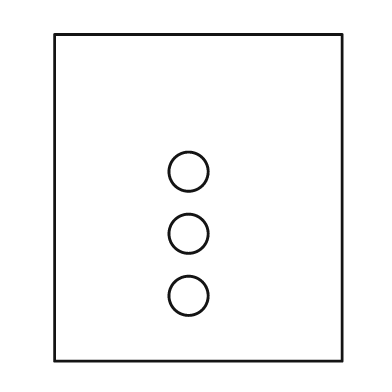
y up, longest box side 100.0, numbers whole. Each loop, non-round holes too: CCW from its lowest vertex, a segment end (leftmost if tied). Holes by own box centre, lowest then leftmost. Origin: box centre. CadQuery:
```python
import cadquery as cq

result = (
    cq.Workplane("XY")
    .moveTo(-44.0, -50.0)
    .lineTo(44.0, -50.0)
    .lineTo(44.0, 50.0)
    .lineTo(-44.0, 50.0)
    .close()
    .moveTo(-3.0, -30.0)
    .circle(6.0)
    .moveTo(-3.0, -11.0)
    .circle(6.0)
    .moveTo(-3.0, 8.0)
    .circle(6.0)
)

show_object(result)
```